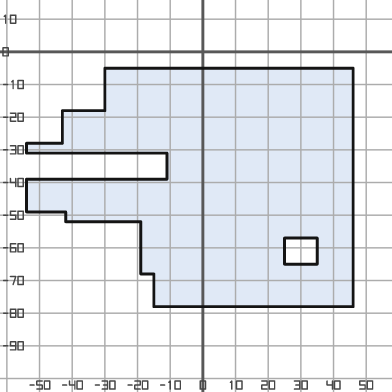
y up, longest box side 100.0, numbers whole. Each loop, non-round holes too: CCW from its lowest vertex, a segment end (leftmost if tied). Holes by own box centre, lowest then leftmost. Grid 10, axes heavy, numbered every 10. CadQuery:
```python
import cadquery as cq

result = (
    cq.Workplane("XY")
    .moveTo(-15.0, -78.0)
    .lineTo(46.0, -78.0)
    .lineTo(46.0, -5.0)
    .lineTo(-30.0, -5.0)
    .lineTo(-30.0, -18.0)
    .lineTo(-43.0, -18.0)
    .lineTo(-43.0, -28.0)
    .lineTo(-54.0, -28.0)
    .lineTo(-54.0, -31.0)
    .lineTo(-11.0, -31.0)
    .lineTo(-11.0, -39.0)
    .lineTo(-54.0, -39.0)
    .lineTo(-54.0, -49.0)
    .lineTo(-42.0, -49.0)
    .lineTo(-42.0, -52.0)
    .lineTo(-19.0, -52.0)
    .lineTo(-19.0, -68.0)
    .lineTo(-15.0, -68.0)
    .close()
    .moveTo(25.0, -65.0)
    .lineTo(35.0, -65.0)
    .lineTo(35.0, -57.0)
    .lineTo(25.0, -57.0)
    .close()
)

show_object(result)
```